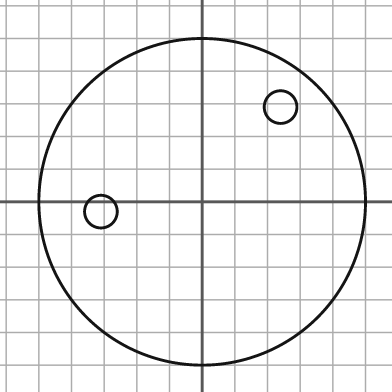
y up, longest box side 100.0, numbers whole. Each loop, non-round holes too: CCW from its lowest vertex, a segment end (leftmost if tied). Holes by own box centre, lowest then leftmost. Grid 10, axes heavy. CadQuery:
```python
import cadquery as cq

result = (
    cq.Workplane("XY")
    .moveTo(0.0, 0.0)
    .circle(50.0)
    .moveTo(-31.0, -3.0)
    .circle(5.0)
    .moveTo(24.0, 29.0)
    .circle(5.0)
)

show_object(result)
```